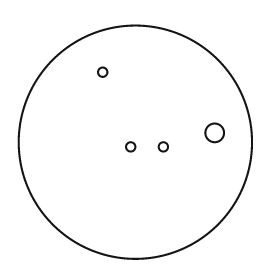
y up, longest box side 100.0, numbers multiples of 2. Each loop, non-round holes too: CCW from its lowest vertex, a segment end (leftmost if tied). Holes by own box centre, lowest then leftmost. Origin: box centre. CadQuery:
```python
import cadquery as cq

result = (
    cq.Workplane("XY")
    .moveTo(0.0, 0.0)
    .circle(50.0)
    .moveTo(-2.0, -2.0)
    .circle(2.0)
    .moveTo(12.0, -2.0)
    .circle(2.0)
    .moveTo(34.0, 4.0)
    .circle(4.0)
    .moveTo(-14.0, 30.0)
    .circle(2.0)
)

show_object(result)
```